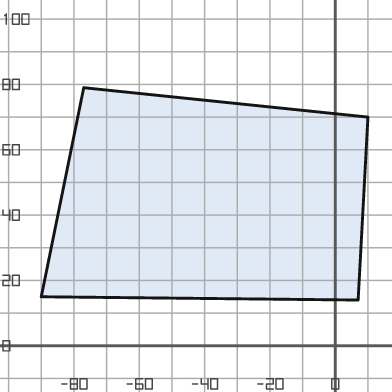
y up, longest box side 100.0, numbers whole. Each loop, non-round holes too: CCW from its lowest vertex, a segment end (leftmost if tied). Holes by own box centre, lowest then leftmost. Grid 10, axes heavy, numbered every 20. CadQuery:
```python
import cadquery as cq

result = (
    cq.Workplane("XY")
    .moveTo(7.0, 14.0)
    .lineTo(10.0, 70.0)
    .lineTo(-77.0, 79.0)
    .lineTo(-90.0, 15.0)
    .close()
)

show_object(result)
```